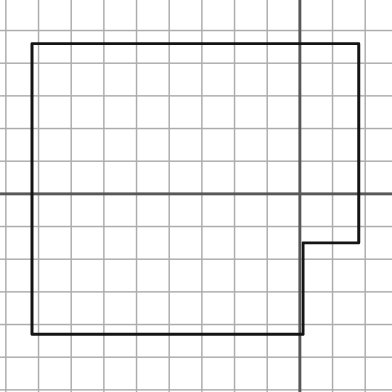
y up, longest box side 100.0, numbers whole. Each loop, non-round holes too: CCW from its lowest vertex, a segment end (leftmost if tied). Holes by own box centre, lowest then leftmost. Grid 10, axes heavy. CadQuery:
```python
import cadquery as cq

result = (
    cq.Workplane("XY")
    .moveTo(-82.0, -43.0)
    .lineTo(1.0, -43.0)
    .lineTo(1.0, -15.0)
    .lineTo(18.0, -15.0)
    .lineTo(18.0, 46.0)
    .lineTo(-82.0, 46.0)
    .close()
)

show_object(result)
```